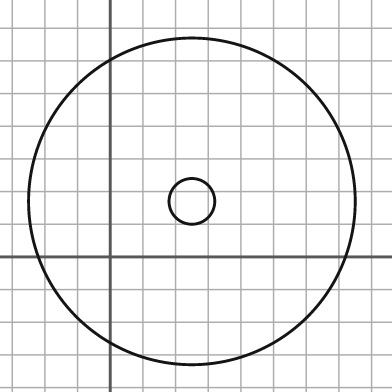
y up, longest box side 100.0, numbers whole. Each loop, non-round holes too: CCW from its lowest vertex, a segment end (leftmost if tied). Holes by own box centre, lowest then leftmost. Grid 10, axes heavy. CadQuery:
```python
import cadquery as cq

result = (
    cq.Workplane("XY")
    .moveTo(25.0, 17.0)
    .circle(50.0)
    .moveTo(25.0, 17.0)
    .circle(7.0)
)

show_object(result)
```